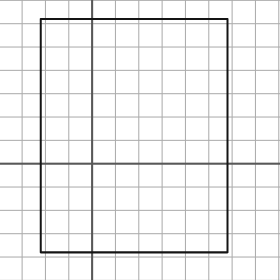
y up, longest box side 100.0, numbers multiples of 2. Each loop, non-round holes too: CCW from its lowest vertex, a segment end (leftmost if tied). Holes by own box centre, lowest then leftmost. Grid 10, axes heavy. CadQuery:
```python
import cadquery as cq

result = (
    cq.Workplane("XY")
    .moveTo(-22.0, -38.0)
    .lineTo(58.0, -38.0)
    .lineTo(58.0, 62.0)
    .lineTo(-22.0, 62.0)
    .close()
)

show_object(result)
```